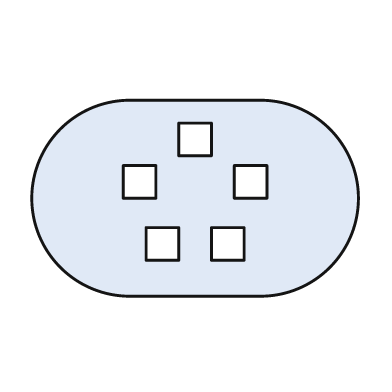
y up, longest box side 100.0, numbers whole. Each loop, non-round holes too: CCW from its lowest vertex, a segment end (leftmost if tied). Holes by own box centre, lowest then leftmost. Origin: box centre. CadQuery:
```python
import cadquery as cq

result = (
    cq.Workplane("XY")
    .moveTo(-20.0, -30.0)
    .lineTo(20.0, -30.0)
    .threePointArc((50.0, 0.0), (20.0, 30.0))
    .lineTo(-20.0, 30.0)
    .threePointArc((-50.0, 0.0), (-20.0, -30.0))
    .close()
    .moveTo(-15.0, -19.0)
    .lineTo(-5.0, -19.0)
    .lineTo(-5.0, -9.0)
    .lineTo(-15.0, -9.0)
    .close()
    .moveTo(5.0, -19.0)
    .lineTo(15.0, -19.0)
    .lineTo(15.0, -9.0)
    .lineTo(5.0, -9.0)
    .close()
    .moveTo(-22.0, 0.0)
    .lineTo(-12.0, 0.0)
    .lineTo(-12.0, 10.0)
    .lineTo(-22.0, 10.0)
    .close()
    .moveTo(12.0, 0.0)
    .lineTo(22.0, 0.0)
    .lineTo(22.0, 10.0)
    .lineTo(12.0, 10.0)
    .close()
    .moveTo(-5.0, 13.0)
    .lineTo(5.0, 13.0)
    .lineTo(5.0, 23.0)
    .lineTo(-5.0, 23.0)
    .close()
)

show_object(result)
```